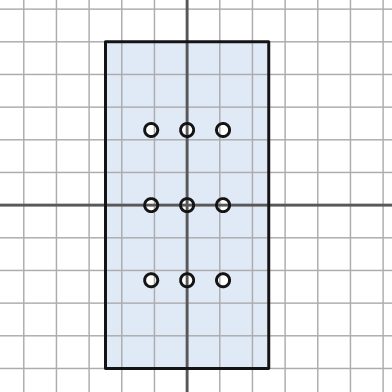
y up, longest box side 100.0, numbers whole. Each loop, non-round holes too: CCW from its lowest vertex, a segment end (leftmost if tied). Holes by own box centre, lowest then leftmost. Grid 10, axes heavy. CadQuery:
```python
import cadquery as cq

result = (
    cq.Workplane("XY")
    .moveTo(-25.0, -50.0)
    .lineTo(25.0, -50.0)
    .lineTo(25.0, 50.0)
    .lineTo(-25.0, 50.0)
    .close()
    .moveTo(-11.0, -23.0)
    .circle(2.0)
    .moveTo(0.0, -23.0)
    .circle(2.0)
    .moveTo(11.0, -23.0)
    .circle(2.0)
    .moveTo(-11.0, 0.0)
    .circle(2.0)
    .moveTo(0.0, 0.0)
    .circle(2.0)
    .moveTo(11.0, 0.0)
    .circle(2.0)
    .moveTo(-11.0, 23.0)
    .circle(2.0)
    .moveTo(0.0, 23.0)
    .circle(2.0)
    .moveTo(11.0, 23.0)
    .circle(2.0)
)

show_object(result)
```